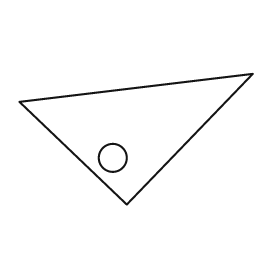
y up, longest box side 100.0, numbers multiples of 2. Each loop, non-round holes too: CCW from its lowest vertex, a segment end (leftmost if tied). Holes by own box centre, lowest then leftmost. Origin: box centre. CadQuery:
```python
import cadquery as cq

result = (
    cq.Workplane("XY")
    .moveTo(-4.0, -28.0)
    .lineTo(50.0, 28.0)
    .lineTo(-50.0, 16.0)
    .close()
    .moveTo(-10.0, -8.0)
    .circle(6.0)
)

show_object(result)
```